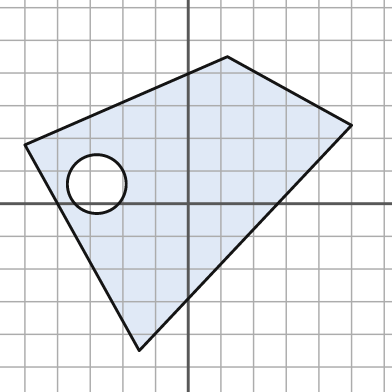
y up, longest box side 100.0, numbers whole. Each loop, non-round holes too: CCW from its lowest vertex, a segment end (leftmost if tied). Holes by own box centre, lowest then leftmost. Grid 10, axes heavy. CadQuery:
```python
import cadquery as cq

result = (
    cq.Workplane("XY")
    .moveTo(-15.0, -45.0)
    .lineTo(50.0, 24.0)
    .lineTo(12.0, 45.0)
    .lineTo(-50.0, 18.0)
    .close()
    .moveTo(-28.0, 6.0)
    .circle(9.0)
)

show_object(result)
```